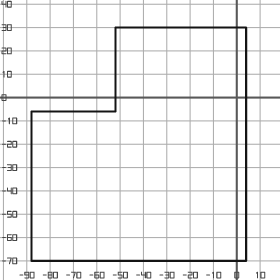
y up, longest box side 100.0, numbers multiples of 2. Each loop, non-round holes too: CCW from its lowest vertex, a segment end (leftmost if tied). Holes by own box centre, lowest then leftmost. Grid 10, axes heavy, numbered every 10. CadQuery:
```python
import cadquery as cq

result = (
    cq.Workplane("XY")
    .moveTo(-88.0, -70.0)
    .lineTo(4.0, -70.0)
    .lineTo(4.0, 30.0)
    .lineTo(-52.0, 30.0)
    .lineTo(-52.0, -6.0)
    .lineTo(-88.0, -6.0)
    .close()
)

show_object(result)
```